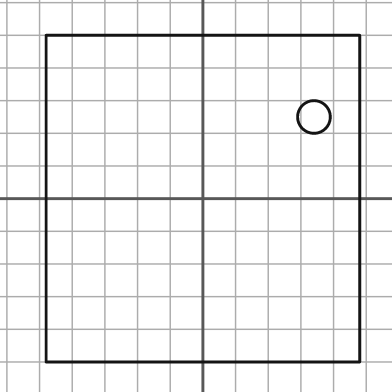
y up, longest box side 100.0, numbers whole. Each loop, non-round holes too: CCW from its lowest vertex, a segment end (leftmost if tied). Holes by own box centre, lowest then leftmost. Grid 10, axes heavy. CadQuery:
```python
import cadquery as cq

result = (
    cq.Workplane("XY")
    .moveTo(-48.0, -50.0)
    .lineTo(48.0, -50.0)
    .lineTo(48.0, 50.0)
    .lineTo(-48.0, 50.0)
    .close()
    .moveTo(34.0, 25.0)
    .circle(5.0)
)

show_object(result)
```